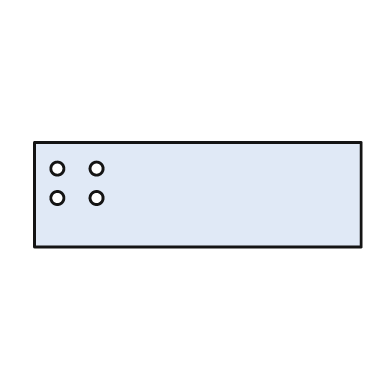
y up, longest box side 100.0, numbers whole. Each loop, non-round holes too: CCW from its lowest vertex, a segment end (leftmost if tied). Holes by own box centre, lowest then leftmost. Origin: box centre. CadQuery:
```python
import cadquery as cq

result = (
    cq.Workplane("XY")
    .moveTo(-50.0, -16.0)
    .lineTo(50.0, -16.0)
    .lineTo(50.0, 16.0)
    .lineTo(-50.0, 16.0)
    .close()
    .moveTo(-43.0, -1.0)
    .circle(2.0)
    .moveTo(-31.0, -1.0)
    .circle(2.0)
    .moveTo(-43.0, 8.0)
    .circle(2.0)
    .moveTo(-31.0, 8.0)
    .circle(2.0)
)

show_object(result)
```